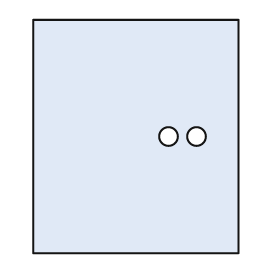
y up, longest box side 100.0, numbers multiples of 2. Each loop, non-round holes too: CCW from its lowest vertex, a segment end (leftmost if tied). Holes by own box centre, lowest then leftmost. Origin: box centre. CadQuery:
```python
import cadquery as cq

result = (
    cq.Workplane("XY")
    .moveTo(-44.0, -50.0)
    .lineTo(44.0, -50.0)
    .lineTo(44.0, 50.0)
    .lineTo(-44.0, 50.0)
    .close()
    .moveTo(14.0, 0.0)
    .circle(4.0)
    .moveTo(26.0, 0.0)
    .circle(4.0)
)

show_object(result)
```